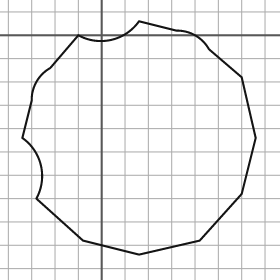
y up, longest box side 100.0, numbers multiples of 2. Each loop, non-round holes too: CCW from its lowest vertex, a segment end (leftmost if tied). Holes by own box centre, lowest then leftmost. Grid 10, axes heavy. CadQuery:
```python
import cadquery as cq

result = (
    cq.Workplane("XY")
    .moveTo(16.0, -94.0)
    .lineTo(42.0, -88.0)
    .lineTo(60.0, -68.0)
    .lineTo(66.0, -44.0)
    .lineTo(60.0, -18.0)
    .lineTo(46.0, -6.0)
    .threePointArc((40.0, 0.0), (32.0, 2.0))
    .lineTo(16.0, 6.0)
    .threePointArc((4.0, -2.0), (-10.0, 0.0))
    .lineTo(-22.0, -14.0)
    .threePointArc((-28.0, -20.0), (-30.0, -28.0))
    .lineTo(-34.0, -44.0)
    .threePointArc((-26.0, -56.0), (-28.0, -70.0))
    .lineTo(-8.0, -88.0)
    .close()
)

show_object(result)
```